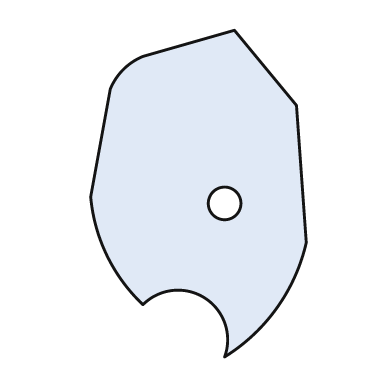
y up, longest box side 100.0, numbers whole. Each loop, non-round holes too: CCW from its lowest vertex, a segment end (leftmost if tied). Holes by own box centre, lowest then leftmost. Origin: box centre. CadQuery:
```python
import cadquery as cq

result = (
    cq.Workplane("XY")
    .moveTo(8.0, -50.0)
    .threePointArc((24.0, -35.0), (33.0, -15.0))
    .lineTo(30.0, 27.0)
    .lineTo(11.0, 50.0)
    .lineTo(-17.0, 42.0)
    .threePointArc((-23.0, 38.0), (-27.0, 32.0))
    .lineTo(-33.0, -1.0)
    .threePointArc((-28.0, -19.0), (-17.0, -34.0))
    .threePointArc((2.0, -32.0), (8.0, -50.0))
    .close()
    .moveTo(8.0, -3.0)
    .circle(5.0)
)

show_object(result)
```